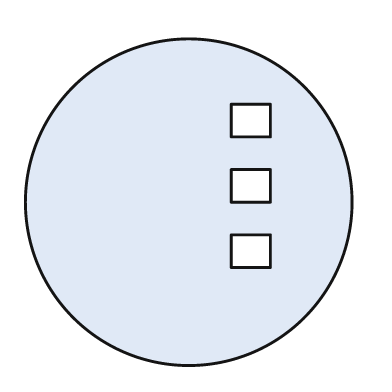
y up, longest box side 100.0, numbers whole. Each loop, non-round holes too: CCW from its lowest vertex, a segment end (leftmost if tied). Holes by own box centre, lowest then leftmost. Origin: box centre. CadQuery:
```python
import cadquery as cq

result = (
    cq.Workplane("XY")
    .moveTo(0.0, 0.0)
    .circle(50.0)
    .moveTo(13.0, -20.0)
    .lineTo(25.0, -20.0)
    .lineTo(25.0, -10.0)
    .lineTo(13.0, -10.0)
    .close()
    .moveTo(13.0, 0.0)
    .lineTo(25.0, 0.0)
    .lineTo(25.0, 10.0)
    .lineTo(13.0, 10.0)
    .close()
    .moveTo(13.0, 20.0)
    .lineTo(25.0, 20.0)
    .lineTo(25.0, 30.0)
    .lineTo(13.0, 30.0)
    .close()
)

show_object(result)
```